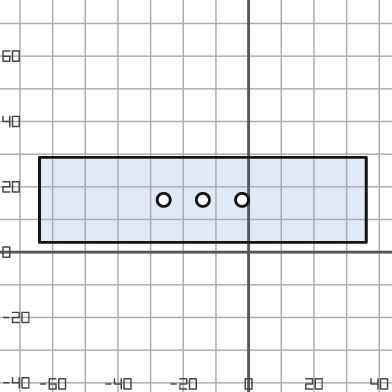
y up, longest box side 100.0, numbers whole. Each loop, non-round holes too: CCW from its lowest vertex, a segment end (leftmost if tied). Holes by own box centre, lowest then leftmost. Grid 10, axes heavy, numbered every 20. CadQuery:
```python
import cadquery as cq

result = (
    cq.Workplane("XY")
    .moveTo(-64.0, 3.0)
    .lineTo(36.0, 3.0)
    .lineTo(36.0, 29.0)
    .lineTo(-64.0, 29.0)
    .close()
    .moveTo(-26.0, 16.0)
    .circle(2.0)
    .moveTo(-14.0, 16.0)
    .circle(2.0)
    .moveTo(-2.0, 16.0)
    .circle(2.0)
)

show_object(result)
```